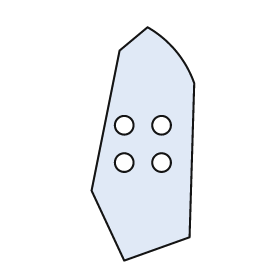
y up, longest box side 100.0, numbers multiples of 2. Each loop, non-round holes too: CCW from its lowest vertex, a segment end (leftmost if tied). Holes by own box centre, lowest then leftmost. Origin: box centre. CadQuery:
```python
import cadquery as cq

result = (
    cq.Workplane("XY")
    .moveTo(-8.0, -50.0)
    .lineTo(20.0, -40.0)
    .lineTo(22.0, 26.0)
    .threePointArc((14.0, 40.0), (2.0, 50.0))
    .lineTo(-10.0, 40.0)
    .lineTo(-22.0, -20.0)
    .close()
    .moveTo(-8.0, -8.0)
    .circle(4.0)
    .moveTo(8.0, -8.0)
    .circle(4.0)
    .moveTo(-8.0, 8.0)
    .circle(4.0)
    .moveTo(8.0, 8.0)
    .circle(4.0)
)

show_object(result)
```